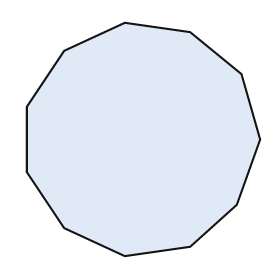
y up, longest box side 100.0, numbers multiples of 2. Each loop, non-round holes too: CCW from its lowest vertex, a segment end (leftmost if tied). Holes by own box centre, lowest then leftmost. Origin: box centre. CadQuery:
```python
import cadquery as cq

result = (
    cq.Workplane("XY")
    .moveTo(-8.0, -50.0)
    .lineTo(20.0, -46.0)
    .lineTo(40.0, -28.0)
    .lineTo(50.0, 0.0)
    .lineTo(42.0, 28.0)
    .lineTo(20.0, 46.0)
    .lineTo(-8.0, 50.0)
    .lineTo(-34.0, 38.0)
    .lineTo(-50.0, 14.0)
    .lineTo(-50.0, -14.0)
    .lineTo(-34.0, -38.0)
    .close()
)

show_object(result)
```